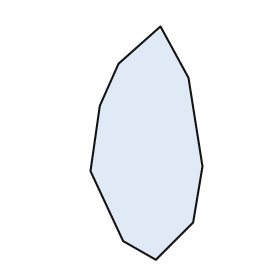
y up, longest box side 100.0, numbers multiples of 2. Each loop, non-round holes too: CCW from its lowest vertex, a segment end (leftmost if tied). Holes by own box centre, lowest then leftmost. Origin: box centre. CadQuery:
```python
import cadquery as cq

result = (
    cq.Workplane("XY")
    .moveTo(4.0, -50.0)
    .lineTo(20.0, -34.0)
    .lineTo(24.0, -10.0)
    .lineTo(18.0, 28.0)
    .lineTo(6.0, 50.0)
    .lineTo(-12.0, 34.0)
    .lineTo(-20.0, 16.0)
    .lineTo(-24.0, -12.0)
    .lineTo(-10.0, -42.0)
    .close()
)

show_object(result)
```